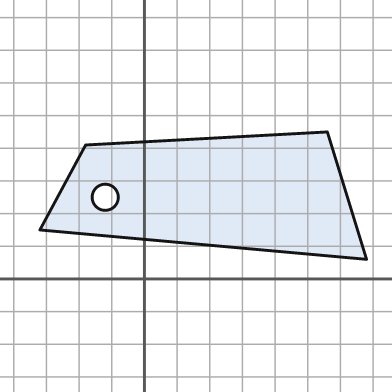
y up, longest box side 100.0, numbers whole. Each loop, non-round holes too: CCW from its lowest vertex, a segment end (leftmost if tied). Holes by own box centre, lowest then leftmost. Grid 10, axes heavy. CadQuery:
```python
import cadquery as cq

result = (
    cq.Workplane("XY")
    .moveTo(68.0, 6.0)
    .lineTo(56.0, 45.0)
    .lineTo(-18.0, 41.0)
    .lineTo(-32.0, 15.0)
    .close()
    .moveTo(-12.0, 25.0)
    .circle(4.0)
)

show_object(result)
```